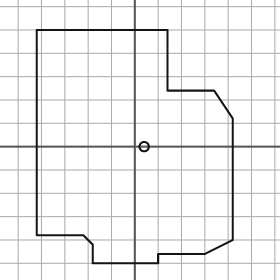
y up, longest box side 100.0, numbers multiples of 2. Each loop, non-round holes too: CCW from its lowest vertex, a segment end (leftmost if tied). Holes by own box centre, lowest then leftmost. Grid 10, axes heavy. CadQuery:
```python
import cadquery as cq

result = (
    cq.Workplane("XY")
    .moveTo(-18.0, -50.0)
    .lineTo(10.0, -50.0)
    .lineTo(10.0, -46.0)
    .lineTo(30.0, -46.0)
    .lineTo(42.0, -40.0)
    .lineTo(42.0, 12.0)
    .lineTo(34.0, 24.0)
    .lineTo(14.0, 24.0)
    .lineTo(14.0, 50.0)
    .lineTo(-42.0, 50.0)
    .lineTo(-42.0, -38.0)
    .lineTo(-22.0, -38.0)
    .lineTo(-18.0, -42.0)
    .close()
    .moveTo(4.0, 0.0)
    .circle(2.0)
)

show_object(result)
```